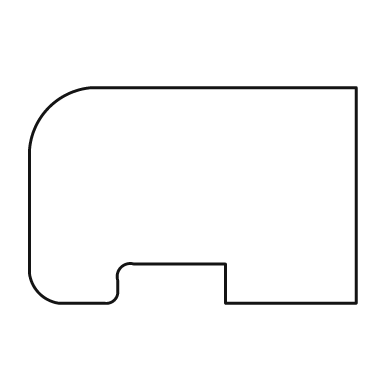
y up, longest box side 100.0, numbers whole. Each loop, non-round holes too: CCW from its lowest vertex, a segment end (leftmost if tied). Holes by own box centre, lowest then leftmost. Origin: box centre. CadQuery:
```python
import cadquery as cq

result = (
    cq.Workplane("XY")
    .moveTo(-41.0, -33.0)
    .lineTo(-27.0, -33.0)
    .threePointArc((-24.0, -32.0), (-23.0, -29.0))
    .lineTo(-23.0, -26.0)
    .threePointArc((-22.0, -22.0), (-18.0, -21.0))
    .lineTo(10.0, -21.0)
    .lineTo(10.0, -33.0)
    .lineTo(50.0, -33.0)
    .lineTo(50.0, 33.0)
    .lineTo(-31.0, 33.0)
    .threePointArc((-44.0, 27.0), (-50.0, 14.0))
    .lineTo(-50.0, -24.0)
    .threePointArc((-47.0, -30.0), (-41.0, -33.0))
    .close()
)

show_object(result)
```